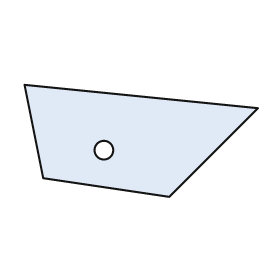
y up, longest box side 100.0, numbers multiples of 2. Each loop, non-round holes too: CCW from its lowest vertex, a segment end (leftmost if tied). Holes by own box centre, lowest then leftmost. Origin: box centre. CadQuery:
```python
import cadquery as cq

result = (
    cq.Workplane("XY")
    .moveTo(12.0, -24.0)
    .lineTo(50.0, 14.0)
    .lineTo(-50.0, 24.0)
    .lineTo(-42.0, -16.0)
    .close()
    .moveTo(-16.0, -4.0)
    .circle(4.0)
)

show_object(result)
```